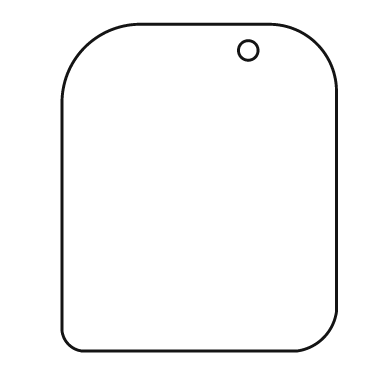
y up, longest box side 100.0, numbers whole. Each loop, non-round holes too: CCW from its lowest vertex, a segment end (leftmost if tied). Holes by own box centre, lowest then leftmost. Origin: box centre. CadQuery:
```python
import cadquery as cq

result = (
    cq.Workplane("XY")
    .moveTo(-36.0, -50.0)
    .lineTo(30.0, -50.0)
    .threePointArc((38.0, -46.0), (42.0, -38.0))
    .lineTo(42.0, 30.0)
    .threePointArc((36.0, 44.0), (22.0, 50.0))
    .lineTo(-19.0, 50.0)
    .threePointArc((-35.0, 43.0), (-42.0, 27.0))
    .lineTo(-42.0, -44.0)
    .threePointArc((-40.0, -48.0), (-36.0, -50.0))
    .close()
    .moveTo(15.0, 42.0)
    .circle(3.0)
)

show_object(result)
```